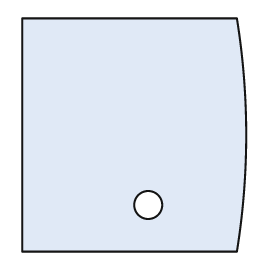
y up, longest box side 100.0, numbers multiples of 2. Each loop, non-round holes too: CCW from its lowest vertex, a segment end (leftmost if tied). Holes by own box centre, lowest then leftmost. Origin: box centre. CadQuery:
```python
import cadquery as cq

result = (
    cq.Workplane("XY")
    .moveTo(-48.0, -50.0)
    .lineTo(44.0, -50.0)
    .threePointArc((48.0, 0.0), (44.0, 50.0))
    .lineTo(-48.0, 50.0)
    .close()
    .moveTo(6.0, -30.0)
    .circle(6.0)
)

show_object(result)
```